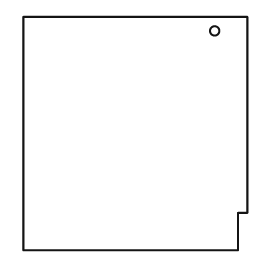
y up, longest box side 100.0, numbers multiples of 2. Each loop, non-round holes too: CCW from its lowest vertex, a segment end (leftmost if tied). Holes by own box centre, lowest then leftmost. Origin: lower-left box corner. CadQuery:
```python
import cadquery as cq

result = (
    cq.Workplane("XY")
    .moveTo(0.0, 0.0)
    .lineTo(92.0, 0.0)
    .lineTo(92.0, 16.0)
    .lineTo(96.0, 16.0)
    .lineTo(96.0, 100.0)
    .lineTo(0.0, 100.0)
    .close()
    .moveTo(82.0, 94.0)
    .circle(2.0)
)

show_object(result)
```